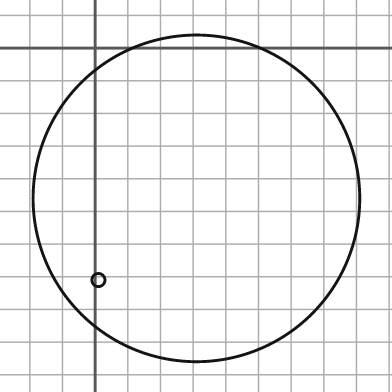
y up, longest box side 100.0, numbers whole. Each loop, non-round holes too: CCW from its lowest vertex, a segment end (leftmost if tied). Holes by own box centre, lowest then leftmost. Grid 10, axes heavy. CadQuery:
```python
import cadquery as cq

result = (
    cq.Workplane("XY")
    .moveTo(31.0, -46.0)
    .circle(50.0)
    .moveTo(1.0, -71.0)
    .circle(2.0)
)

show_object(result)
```